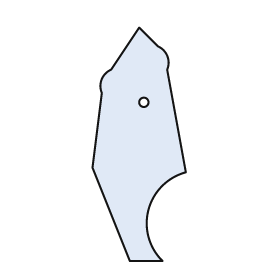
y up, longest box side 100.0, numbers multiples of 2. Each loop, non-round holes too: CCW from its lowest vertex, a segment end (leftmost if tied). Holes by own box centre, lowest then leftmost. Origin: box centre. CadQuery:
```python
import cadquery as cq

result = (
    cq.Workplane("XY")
    .moveTo(-4.0, -50.0)
    .lineTo(10.0, -50.0)
    .threePointArc((4.0, -28.0), (20.0, -12.0))
    .lineTo(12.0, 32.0)
    .threePointArc((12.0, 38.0), (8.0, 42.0))
    .lineTo(0.0, 50.0)
    .lineTo(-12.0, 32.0)
    .threePointArc((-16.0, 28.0), (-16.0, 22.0))
    .lineTo(-20.0, -10.0)
    .close()
    .moveTo(2.0, 18.0)
    .circle(2.0)
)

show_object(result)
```